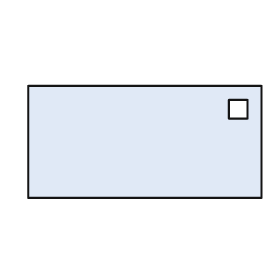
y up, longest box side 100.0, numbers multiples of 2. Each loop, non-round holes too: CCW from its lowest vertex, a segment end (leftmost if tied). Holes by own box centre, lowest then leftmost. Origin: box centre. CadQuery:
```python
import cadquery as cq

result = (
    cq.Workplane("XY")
    .moveTo(-50.0, -24.0)
    .lineTo(50.0, -24.0)
    .lineTo(50.0, 24.0)
    .lineTo(-50.0, 24.0)
    .close()
    .moveTo(36.0, 10.0)
    .lineTo(44.0, 10.0)
    .lineTo(44.0, 18.0)
    .lineTo(36.0, 18.0)
    .close()
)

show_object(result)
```